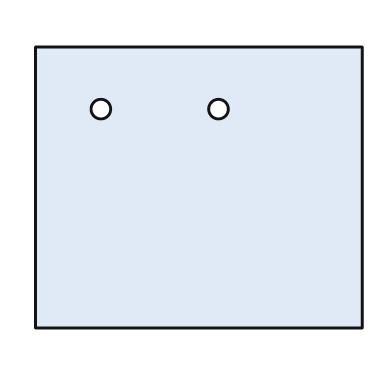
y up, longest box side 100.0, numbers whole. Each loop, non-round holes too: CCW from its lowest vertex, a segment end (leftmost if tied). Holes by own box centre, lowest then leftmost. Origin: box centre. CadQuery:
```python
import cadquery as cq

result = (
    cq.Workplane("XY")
    .moveTo(-50.0, -43.0)
    .lineTo(50.0, -43.0)
    .lineTo(50.0, 43.0)
    .lineTo(-50.0, 43.0)
    .close()
    .moveTo(-30.0, 24.0)
    .circle(3.0)
    .moveTo(6.0, 24.0)
    .circle(3.0)
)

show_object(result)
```